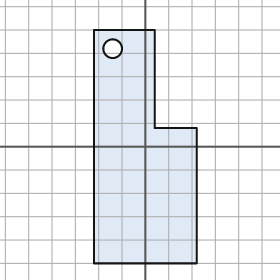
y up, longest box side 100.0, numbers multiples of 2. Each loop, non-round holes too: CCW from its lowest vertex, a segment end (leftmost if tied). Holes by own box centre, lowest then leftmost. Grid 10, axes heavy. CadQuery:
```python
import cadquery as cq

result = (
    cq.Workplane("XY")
    .moveTo(-22.0, -50.0)
    .lineTo(22.0, -50.0)
    .lineTo(22.0, 8.0)
    .lineTo(4.0, 8.0)
    .lineTo(4.0, 50.0)
    .lineTo(-22.0, 50.0)
    .close()
    .moveTo(-14.0, 42.0)
    .circle(4.0)
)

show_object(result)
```